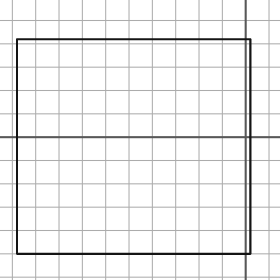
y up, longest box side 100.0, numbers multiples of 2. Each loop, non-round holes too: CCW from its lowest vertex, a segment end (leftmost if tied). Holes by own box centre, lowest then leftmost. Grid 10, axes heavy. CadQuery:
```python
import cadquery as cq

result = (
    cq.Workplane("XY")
    .moveTo(-98.0, -50.0)
    .lineTo(2.0, -50.0)
    .lineTo(2.0, 42.0)
    .lineTo(-98.0, 42.0)
    .close()
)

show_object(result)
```